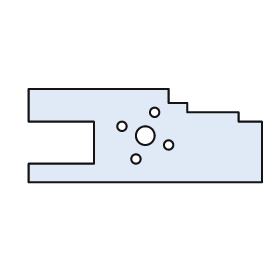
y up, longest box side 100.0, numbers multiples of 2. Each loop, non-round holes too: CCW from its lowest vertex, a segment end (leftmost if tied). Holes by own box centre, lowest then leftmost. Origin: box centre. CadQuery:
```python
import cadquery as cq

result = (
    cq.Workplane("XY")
    .moveTo(-50.0, -20.0)
    .lineTo(50.0, -20.0)
    .lineTo(50.0, 6.0)
    .lineTo(40.0, 6.0)
    .lineTo(40.0, 10.0)
    .lineTo(18.0, 10.0)
    .lineTo(18.0, 14.0)
    .lineTo(10.0, 14.0)
    .lineTo(10.0, 20.0)
    .lineTo(-50.0, 20.0)
    .lineTo(-50.0, 6.0)
    .lineTo(-22.0, 6.0)
    .lineTo(-22.0, -12.0)
    .lineTo(-50.0, -12.0)
    .close()
    .moveTo(-4.0, -10.0)
    .circle(2.0)
    .moveTo(10.0, -4.0)
    .circle(2.0)
    .moveTo(0.0, 0.0)
    .circle(4.0)
    .moveTo(-10.0, 4.0)
    .circle(2.0)
    .moveTo(4.0, 10.0)
    .circle(2.0)
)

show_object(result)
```